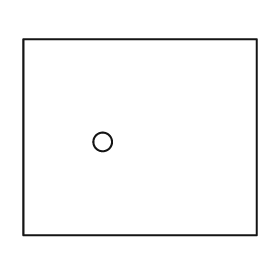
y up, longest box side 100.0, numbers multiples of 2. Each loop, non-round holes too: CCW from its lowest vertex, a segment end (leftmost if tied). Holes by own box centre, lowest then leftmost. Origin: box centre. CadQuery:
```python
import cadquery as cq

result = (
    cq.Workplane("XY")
    .moveTo(-50.0, -42.0)
    .lineTo(50.0, -42.0)
    .lineTo(50.0, 42.0)
    .lineTo(-50.0, 42.0)
    .close()
    .moveTo(-16.0, -2.0)
    .circle(4.0)
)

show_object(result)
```